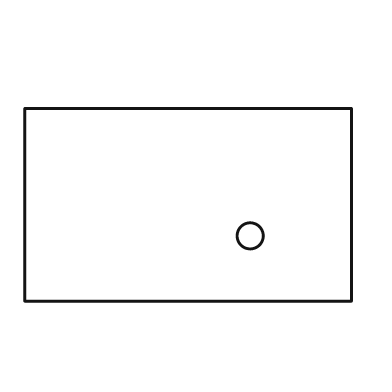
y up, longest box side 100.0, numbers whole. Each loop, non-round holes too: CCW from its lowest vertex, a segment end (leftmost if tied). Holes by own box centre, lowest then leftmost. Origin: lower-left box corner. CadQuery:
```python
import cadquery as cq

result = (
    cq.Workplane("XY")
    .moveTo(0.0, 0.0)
    .lineTo(100.0, 0.0)
    .lineTo(100.0, 59.0)
    .lineTo(0.0, 59.0)
    .close()
    .moveTo(69.0, 20.0)
    .circle(4.0)
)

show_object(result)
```